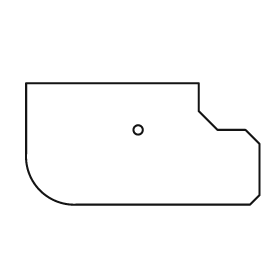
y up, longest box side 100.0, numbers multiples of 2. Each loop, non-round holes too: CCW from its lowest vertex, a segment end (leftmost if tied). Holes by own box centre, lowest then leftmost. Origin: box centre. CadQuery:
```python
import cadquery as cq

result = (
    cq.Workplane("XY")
    .moveTo(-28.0, -26.0)
    .lineTo(46.0, -26.0)
    .lineTo(50.0, -22.0)
    .lineTo(50.0, 0.0)
    .lineTo(44.0, 6.0)
    .lineTo(32.0, 6.0)
    .lineTo(24.0, 14.0)
    .lineTo(24.0, 26.0)
    .lineTo(-50.0, 26.0)
    .lineTo(-50.0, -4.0)
    .threePointArc((-44.0, -20.0), (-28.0, -26.0))
    .close()
    .moveTo(-2.0, 6.0)
    .circle(2.0)
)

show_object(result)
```